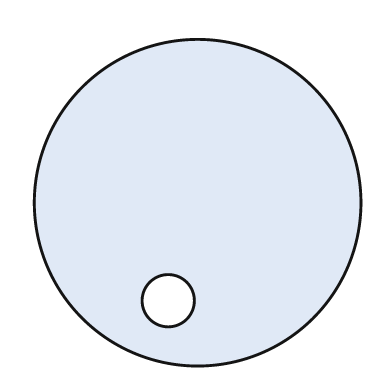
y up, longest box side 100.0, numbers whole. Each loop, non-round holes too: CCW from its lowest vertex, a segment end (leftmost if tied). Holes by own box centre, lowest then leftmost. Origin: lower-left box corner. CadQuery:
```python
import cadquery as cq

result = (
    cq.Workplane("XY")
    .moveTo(50.0, 50.0)
    .circle(50.0)
    .moveTo(41.0, 20.0)
    .circle(8.0)
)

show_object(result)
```